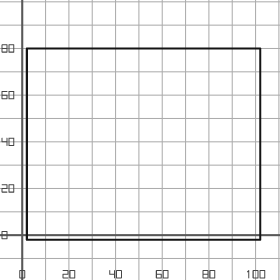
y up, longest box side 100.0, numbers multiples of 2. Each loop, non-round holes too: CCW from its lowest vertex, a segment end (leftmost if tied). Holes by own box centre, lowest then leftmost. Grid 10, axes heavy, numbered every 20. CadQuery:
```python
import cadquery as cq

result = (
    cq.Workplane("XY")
    .moveTo(2.0, -2.0)
    .lineTo(102.0, -2.0)
    .lineTo(102.0, 80.0)
    .lineTo(2.0, 80.0)
    .close()
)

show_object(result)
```